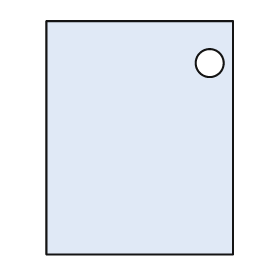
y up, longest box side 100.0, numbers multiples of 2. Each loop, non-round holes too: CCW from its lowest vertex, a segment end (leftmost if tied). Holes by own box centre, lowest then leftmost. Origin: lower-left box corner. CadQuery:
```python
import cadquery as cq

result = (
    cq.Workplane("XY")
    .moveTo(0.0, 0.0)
    .lineTo(80.0, 0.0)
    .lineTo(80.0, 100.0)
    .lineTo(0.0, 100.0)
    .close()
    .moveTo(70.0, 82.0)
    .circle(6.0)
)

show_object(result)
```